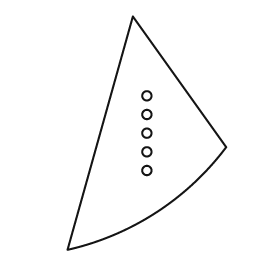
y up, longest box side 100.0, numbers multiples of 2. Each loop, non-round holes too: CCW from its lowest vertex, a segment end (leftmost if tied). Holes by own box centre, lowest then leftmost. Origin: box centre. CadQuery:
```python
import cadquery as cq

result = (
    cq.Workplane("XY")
    .moveTo(-34.0, -50.0)
    .threePointArc((4.0, -34.0), (34.0, -6.0))
    .lineTo(-6.0, 50.0)
    .close()
    .moveTo(0.0, -16.0)
    .circle(2.0)
    .moveTo(0.0, -8.0)
    .circle(2.0)
    .moveTo(0.0, 0.0)
    .circle(2.0)
    .moveTo(0.0, 8.0)
    .circle(2.0)
    .moveTo(0.0, 16.0)
    .circle(2.0)
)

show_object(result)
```